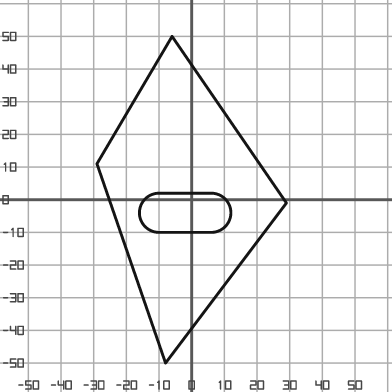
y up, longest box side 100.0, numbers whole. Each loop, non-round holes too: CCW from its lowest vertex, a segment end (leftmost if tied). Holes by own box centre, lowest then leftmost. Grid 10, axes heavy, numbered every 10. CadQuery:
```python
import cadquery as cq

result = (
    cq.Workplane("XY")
    .moveTo(-8.0, -50.0)
    .lineTo(29.0, -1.0)
    .lineTo(-6.0, 50.0)
    .lineTo(-29.0, 11.0)
    .close()
    .moveTo(-10.0, -10.0)
    .lineTo(6.0, -10.0)
    .threePointArc((12.0, -4.0), (6.0, 2.0))
    .lineTo(-10.0, 2.0)
    .threePointArc((-16.0, -4.0), (-10.0, -10.0))
    .close()
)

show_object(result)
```